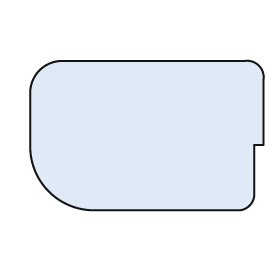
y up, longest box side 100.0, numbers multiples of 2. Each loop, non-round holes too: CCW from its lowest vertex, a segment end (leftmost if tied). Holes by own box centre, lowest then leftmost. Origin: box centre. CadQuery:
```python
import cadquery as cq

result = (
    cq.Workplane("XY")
    .moveTo(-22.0, -32.0)
    .lineTo(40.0, -32.0)
    .threePointArc((44.0, -30.0), (46.0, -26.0))
    .lineTo(46.0, -4.0)
    .lineTo(50.0, -4.0)
    .lineTo(50.0, 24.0)
    .threePointArc((48.0, 30.0), (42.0, 32.0))
    .lineTo(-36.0, 32.0)
    .threePointArc((-46.0, 28.0), (-50.0, 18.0))
    .lineTo(-50.0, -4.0)
    .threePointArc((-42.0, -24.0), (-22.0, -32.0))
    .close()
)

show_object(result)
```